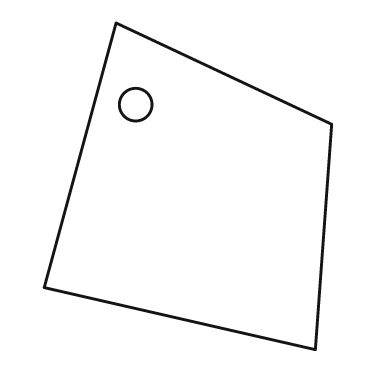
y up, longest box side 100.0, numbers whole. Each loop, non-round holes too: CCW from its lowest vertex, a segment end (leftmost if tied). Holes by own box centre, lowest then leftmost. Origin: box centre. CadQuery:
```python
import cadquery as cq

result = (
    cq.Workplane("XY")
    .moveTo(39.0, -50.0)
    .lineTo(44.0, 19.0)
    .lineTo(-22.0, 50.0)
    .lineTo(-44.0, -31.0)
    .close()
    .moveTo(-16.0, 25.0)
    .circle(5.0)
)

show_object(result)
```